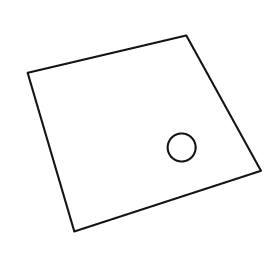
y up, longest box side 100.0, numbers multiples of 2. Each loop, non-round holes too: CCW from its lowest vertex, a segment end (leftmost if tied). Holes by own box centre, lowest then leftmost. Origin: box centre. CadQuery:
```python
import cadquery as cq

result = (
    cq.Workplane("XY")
    .moveTo(-30.0, -42.0)
    .lineTo(50.0, -16.0)
    .lineTo(18.0, 42.0)
    .lineTo(-50.0, 26.0)
    .close()
    .moveTo(16.0, -6.0)
    .circle(6.0)
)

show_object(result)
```